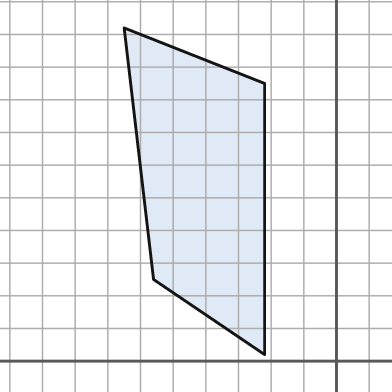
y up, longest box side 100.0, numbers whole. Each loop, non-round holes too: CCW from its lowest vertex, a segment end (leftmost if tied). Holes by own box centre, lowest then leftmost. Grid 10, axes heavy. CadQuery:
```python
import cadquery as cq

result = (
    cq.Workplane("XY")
    .moveTo(-22.0, 2.0)
    .lineTo(-22.0, 85.0)
    .lineTo(-65.0, 102.0)
    .lineTo(-56.0, 25.0)
    .close()
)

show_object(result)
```